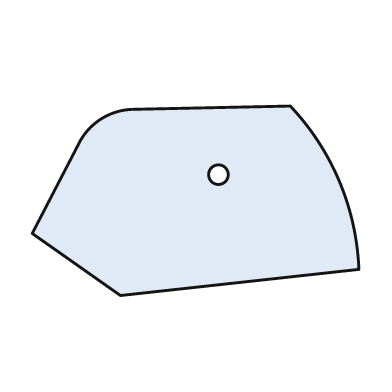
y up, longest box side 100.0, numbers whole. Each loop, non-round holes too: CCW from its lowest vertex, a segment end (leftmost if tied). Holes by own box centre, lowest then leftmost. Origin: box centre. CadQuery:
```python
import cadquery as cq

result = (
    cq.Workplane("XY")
    .moveTo(-23.0, -29.0)
    .lineTo(50.0, -21.0)
    .threePointArc((44.0, 6.0), (29.0, 29.0))
    .lineTo(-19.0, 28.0)
    .threePointArc((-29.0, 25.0), (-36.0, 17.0))
    .lineTo(-50.0, -10.0)
    .close()
    .moveTo(7.0, 8.0)
    .circle(3.0)
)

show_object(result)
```